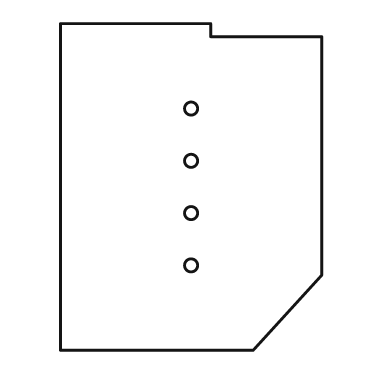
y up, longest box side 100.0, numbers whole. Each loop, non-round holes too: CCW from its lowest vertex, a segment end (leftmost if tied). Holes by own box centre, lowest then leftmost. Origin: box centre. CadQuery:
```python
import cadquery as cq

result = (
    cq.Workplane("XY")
    .moveTo(-40.0, -50.0)
    .lineTo(19.0, -50.0)
    .lineTo(40.0, -27.0)
    .lineTo(40.0, 46.0)
    .lineTo(6.0, 46.0)
    .lineTo(6.0, 50.0)
    .lineTo(-40.0, 50.0)
    .close()
    .moveTo(0.0, -24.0)
    .circle(2.0)
    .moveTo(0.0, -8.0)
    .circle(2.0)
    .moveTo(0.0, 8.0)
    .circle(2.0)
    .moveTo(0.0, 24.0)
    .circle(2.0)
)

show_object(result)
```